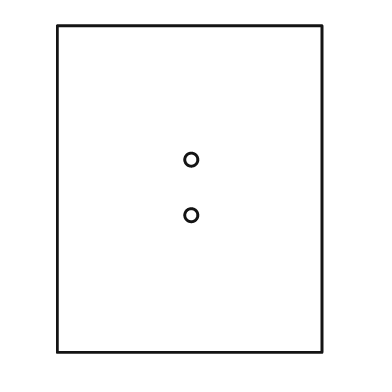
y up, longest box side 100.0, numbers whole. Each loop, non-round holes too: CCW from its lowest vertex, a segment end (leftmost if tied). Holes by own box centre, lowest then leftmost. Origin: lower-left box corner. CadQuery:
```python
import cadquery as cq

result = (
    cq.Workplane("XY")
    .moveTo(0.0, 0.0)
    .lineTo(81.0, 0.0)
    .lineTo(81.0, 100.0)
    .lineTo(0.0, 100.0)
    .close()
    .moveTo(41.0, 42.0)
    .circle(2.0)
    .moveTo(41.0, 59.0)
    .circle(2.0)
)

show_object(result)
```